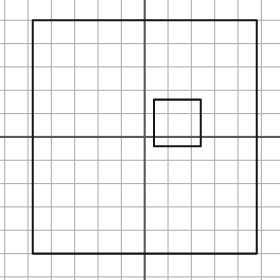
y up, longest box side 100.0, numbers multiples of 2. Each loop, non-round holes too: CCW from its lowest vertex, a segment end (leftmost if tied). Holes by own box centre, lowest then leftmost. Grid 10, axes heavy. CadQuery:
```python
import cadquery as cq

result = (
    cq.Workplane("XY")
    .moveTo(-48.0, -50.0)
    .lineTo(48.0, -50.0)
    .lineTo(48.0, 50.0)
    .lineTo(-48.0, 50.0)
    .close()
    .moveTo(4.0, -4.0)
    .lineTo(24.0, -4.0)
    .lineTo(24.0, 16.0)
    .lineTo(4.0, 16.0)
    .close()
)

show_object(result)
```